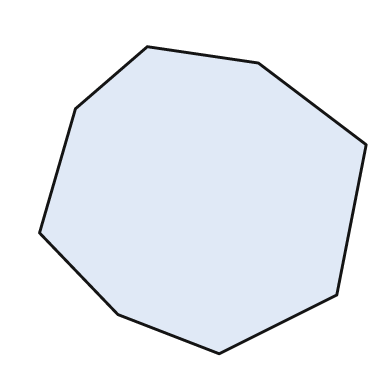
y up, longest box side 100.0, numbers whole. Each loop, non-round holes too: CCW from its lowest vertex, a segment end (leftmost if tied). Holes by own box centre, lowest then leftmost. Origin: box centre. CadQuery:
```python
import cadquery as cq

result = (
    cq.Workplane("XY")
    .moveTo(5.0, -47.0)
    .lineTo(41.0, -29.0)
    .lineTo(50.0, 17.0)
    .lineTo(17.0, 42.0)
    .lineTo(-17.0, 47.0)
    .lineTo(-39.0, 28.0)
    .lineTo(-50.0, -10.0)
    .lineTo(-26.0, -35.0)
    .close()
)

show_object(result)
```